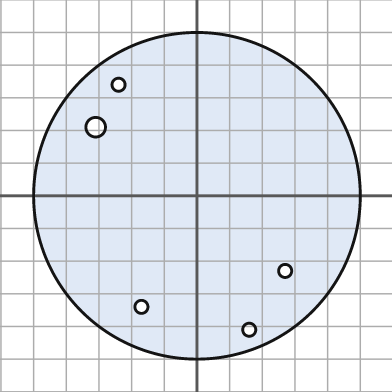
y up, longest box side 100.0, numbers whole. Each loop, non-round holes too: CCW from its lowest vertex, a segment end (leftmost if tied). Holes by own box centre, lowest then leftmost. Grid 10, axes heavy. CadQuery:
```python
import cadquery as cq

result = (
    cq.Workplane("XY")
    .moveTo(0.0, 0.0)
    .circle(50.0)
    .moveTo(16.0, -41.0)
    .circle(2.0)
    .moveTo(-17.0, -34.0)
    .circle(2.0)
    .moveTo(27.0, -23.0)
    .circle(2.0)
    .moveTo(-31.0, 21.0)
    .circle(3.0)
    .moveTo(-24.0, 34.0)
    .circle(2.0)
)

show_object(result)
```